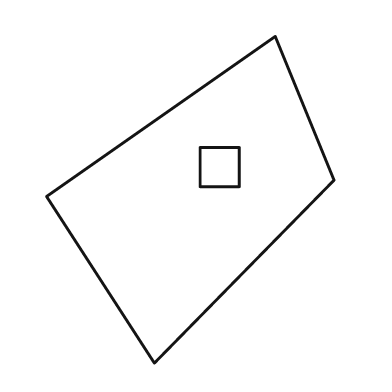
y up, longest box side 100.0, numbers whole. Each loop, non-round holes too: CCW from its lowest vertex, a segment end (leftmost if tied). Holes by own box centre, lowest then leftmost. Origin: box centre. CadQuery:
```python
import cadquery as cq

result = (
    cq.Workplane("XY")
    .moveTo(-11.0, -50.0)
    .lineTo(44.0, 6.0)
    .lineTo(26.0, 50.0)
    .lineTo(-44.0, 1.0)
    .close()
    .moveTo(3.0, 4.0)
    .lineTo(15.0, 4.0)
    .lineTo(15.0, 16.0)
    .lineTo(3.0, 16.0)
    .close()
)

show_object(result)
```